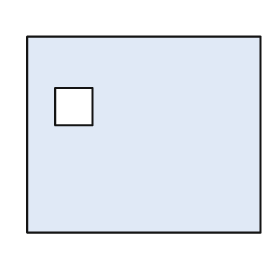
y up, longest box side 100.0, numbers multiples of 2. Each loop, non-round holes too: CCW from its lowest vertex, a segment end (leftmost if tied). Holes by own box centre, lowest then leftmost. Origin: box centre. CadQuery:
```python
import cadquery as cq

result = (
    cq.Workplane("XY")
    .moveTo(-50.0, -42.0)
    .lineTo(50.0, -42.0)
    .lineTo(50.0, 42.0)
    .lineTo(-50.0, 42.0)
    .close()
    .moveTo(-38.0, 4.0)
    .lineTo(-22.0, 4.0)
    .lineTo(-22.0, 20.0)
    .lineTo(-38.0, 20.0)
    .close()
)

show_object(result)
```